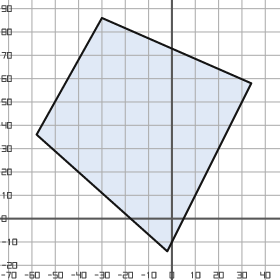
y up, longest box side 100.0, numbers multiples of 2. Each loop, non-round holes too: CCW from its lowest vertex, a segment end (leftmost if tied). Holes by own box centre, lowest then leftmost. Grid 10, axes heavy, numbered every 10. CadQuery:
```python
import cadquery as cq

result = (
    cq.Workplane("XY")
    .moveTo(-2.0, -14.0)
    .lineTo(34.0, 58.0)
    .lineTo(-30.0, 86.0)
    .lineTo(-58.0, 36.0)
    .close()
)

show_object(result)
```